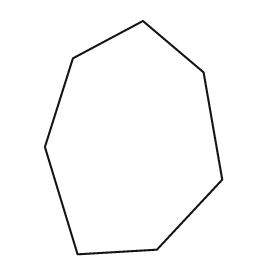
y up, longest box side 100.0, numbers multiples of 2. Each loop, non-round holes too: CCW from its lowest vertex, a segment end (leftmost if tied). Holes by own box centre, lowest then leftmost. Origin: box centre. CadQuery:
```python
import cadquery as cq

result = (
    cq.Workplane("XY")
    .moveTo(-24.0, -50.0)
    .lineTo(10.0, -48.0)
    .lineTo(38.0, -18.0)
    .lineTo(30.0, 28.0)
    .lineTo(4.0, 50.0)
    .lineTo(-26.0, 34.0)
    .lineTo(-38.0, -4.0)
    .close()
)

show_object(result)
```